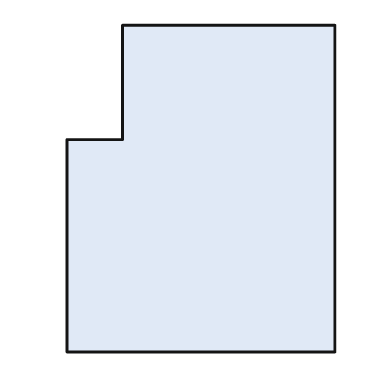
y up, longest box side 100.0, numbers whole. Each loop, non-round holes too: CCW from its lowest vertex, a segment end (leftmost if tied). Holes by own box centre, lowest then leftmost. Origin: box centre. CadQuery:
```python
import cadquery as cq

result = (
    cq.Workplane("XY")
    .moveTo(-41.0, -50.0)
    .lineTo(41.0, -50.0)
    .lineTo(41.0, 50.0)
    .lineTo(-24.0, 50.0)
    .lineTo(-24.0, 15.0)
    .lineTo(-41.0, 15.0)
    .close()
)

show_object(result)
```